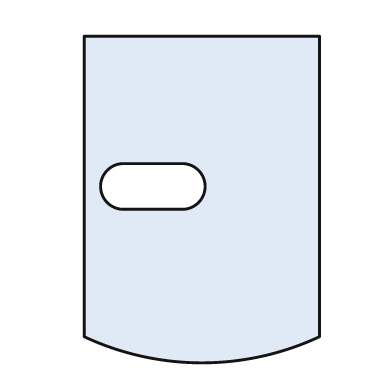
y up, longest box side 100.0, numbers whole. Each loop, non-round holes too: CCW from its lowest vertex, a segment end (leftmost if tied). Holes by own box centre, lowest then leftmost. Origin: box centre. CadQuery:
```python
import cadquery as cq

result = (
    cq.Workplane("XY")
    .moveTo(-36.0, -42.0)
    .threePointArc((0.0, -50.0), (36.0, -42.0))
    .lineTo(36.0, 50.0)
    .lineTo(-36.0, 50.0)
    .close()
    .moveTo(-24.0, -3.0)
    .lineTo(-6.0, -3.0)
    .threePointArc((1.0, 4.0), (-6.0, 11.0))
    .lineTo(-24.0, 11.0)
    .threePointArc((-31.0, 4.0), (-24.0, -3.0))
    .close()
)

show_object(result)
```